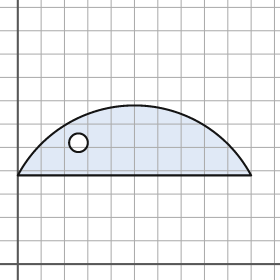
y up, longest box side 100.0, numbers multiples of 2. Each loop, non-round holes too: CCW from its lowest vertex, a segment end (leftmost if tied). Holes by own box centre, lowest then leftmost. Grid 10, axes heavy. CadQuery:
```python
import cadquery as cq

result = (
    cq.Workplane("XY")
    .moveTo(0.0, 38.0)
    .lineTo(100.0, 38.0)
    .threePointArc((50.0, 68.0), (0.0, 38.0))
    .close()
    .moveTo(26.0, 52.0)
    .circle(4.0)
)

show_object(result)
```